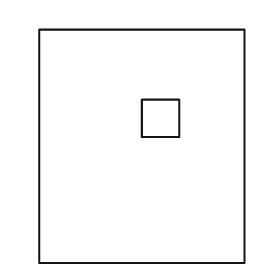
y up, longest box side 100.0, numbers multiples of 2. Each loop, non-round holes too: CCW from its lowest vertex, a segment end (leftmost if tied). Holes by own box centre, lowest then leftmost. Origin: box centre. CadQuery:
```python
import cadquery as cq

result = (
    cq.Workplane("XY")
    .moveTo(-44.0, -50.0)
    .lineTo(44.0, -50.0)
    .lineTo(44.0, 50.0)
    .lineTo(-44.0, 50.0)
    .close()
    .moveTo(0.0, 4.0)
    .lineTo(16.0, 4.0)
    .lineTo(16.0, 20.0)
    .lineTo(0.0, 20.0)
    .close()
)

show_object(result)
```